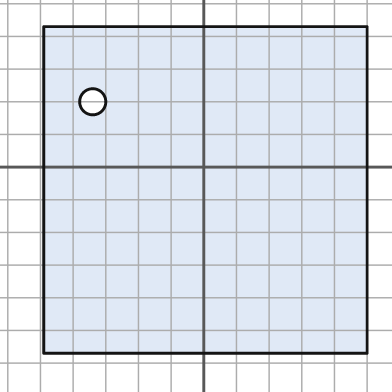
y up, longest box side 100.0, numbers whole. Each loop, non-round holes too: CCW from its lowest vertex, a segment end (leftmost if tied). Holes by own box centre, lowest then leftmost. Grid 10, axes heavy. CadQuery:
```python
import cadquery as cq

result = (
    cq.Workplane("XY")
    .moveTo(-49.0, -57.0)
    .lineTo(50.0, -57.0)
    .lineTo(50.0, 43.0)
    .lineTo(-49.0, 43.0)
    .close()
    .moveTo(-34.0, 20.0)
    .circle(4.0)
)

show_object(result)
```